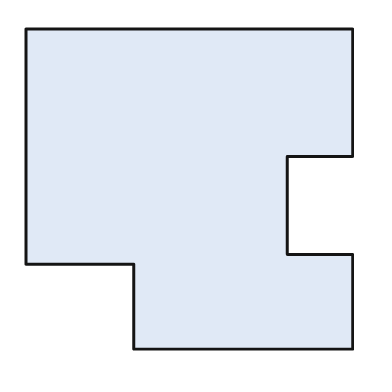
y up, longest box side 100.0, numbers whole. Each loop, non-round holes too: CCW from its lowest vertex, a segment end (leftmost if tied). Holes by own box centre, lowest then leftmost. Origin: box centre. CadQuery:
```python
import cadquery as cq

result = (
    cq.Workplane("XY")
    .moveTo(-17.0, -49.0)
    .lineTo(50.0, -49.0)
    .lineTo(50.0, -20.0)
    .lineTo(30.0, -20.0)
    .lineTo(30.0, 10.0)
    .lineTo(50.0, 10.0)
    .lineTo(50.0, 49.0)
    .lineTo(-50.0, 49.0)
    .lineTo(-50.0, -23.0)
    .lineTo(-17.0, -23.0)
    .close()
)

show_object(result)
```